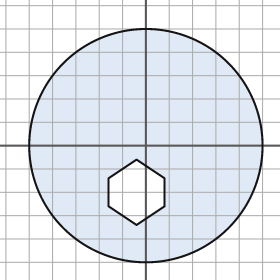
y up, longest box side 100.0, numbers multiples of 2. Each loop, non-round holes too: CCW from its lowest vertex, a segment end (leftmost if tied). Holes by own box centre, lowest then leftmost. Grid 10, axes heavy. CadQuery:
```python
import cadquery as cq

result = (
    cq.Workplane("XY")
    .moveTo(0.0, 0.0)
    .circle(50.0)
    .moveTo(-4.0, -34.0)
    .lineTo(8.0, -26.0)
    .lineTo(8.0, -14.0)
    .lineTo(-4.0, -6.0)
    .lineTo(-16.0, -14.0)
    .lineTo(-16.0, -26.0)
    .close()
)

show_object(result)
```